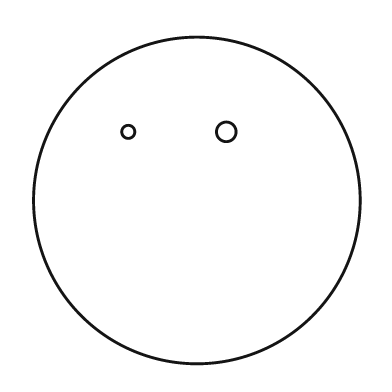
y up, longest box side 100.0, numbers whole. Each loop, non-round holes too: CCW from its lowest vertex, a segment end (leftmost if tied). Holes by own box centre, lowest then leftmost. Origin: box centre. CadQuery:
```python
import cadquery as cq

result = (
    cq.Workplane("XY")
    .moveTo(0.0, 0.0)
    .circle(50.0)
    .moveTo(-21.0, 21.0)
    .circle(2.0)
    .moveTo(9.0, 21.0)
    .circle(3.0)
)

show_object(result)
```